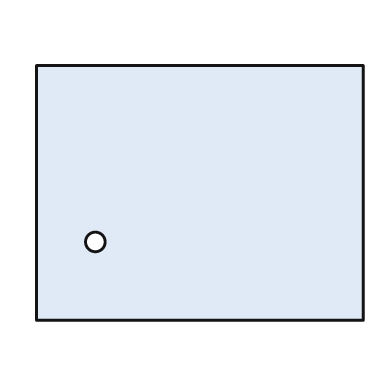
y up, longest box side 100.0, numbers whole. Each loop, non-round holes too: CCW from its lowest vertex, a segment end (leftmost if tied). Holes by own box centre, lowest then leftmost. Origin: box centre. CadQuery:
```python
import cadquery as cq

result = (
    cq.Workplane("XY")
    .moveTo(-50.0, -39.0)
    .lineTo(50.0, -39.0)
    .lineTo(50.0, 39.0)
    .lineTo(-50.0, 39.0)
    .close()
    .moveTo(-32.0, -15.0)
    .circle(3.0)
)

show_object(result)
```